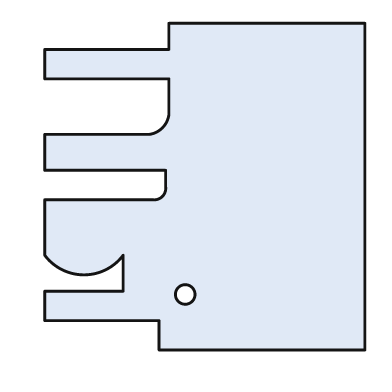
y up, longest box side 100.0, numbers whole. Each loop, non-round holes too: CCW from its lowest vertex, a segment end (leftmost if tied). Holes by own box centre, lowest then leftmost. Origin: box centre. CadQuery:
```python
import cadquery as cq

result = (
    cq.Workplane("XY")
    .moveTo(-14.0, -50.0)
    .lineTo(49.0, -50.0)
    .lineTo(49.0, 50.0)
    .lineTo(-11.0, 50.0)
    .lineTo(-11.0, 42.0)
    .lineTo(-49.0, 42.0)
    .lineTo(-49.0, 33.0)
    .lineTo(-11.0, 33.0)
    .lineTo(-11.0, 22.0)
    .threePointArc((-13.0, 18.0), (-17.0, 16.0))
    .lineTo(-49.0, 16.0)
    .lineTo(-49.0, 5.0)
    .lineTo(-12.0, 5.0)
    .lineTo(-12.0, 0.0)
    .threePointArc((-13.0, -3.0), (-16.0, -4.0))
    .lineTo(-49.0, -4.0)
    .lineTo(-49.0, -21.0)
    .threePointArc((-37.0, -27.0), (-25.0, -21.0))
    .lineTo(-25.0, -32.0)
    .lineTo(-49.0, -32.0)
    .lineTo(-49.0, -41.0)
    .lineTo(-14.0, -41.0)
    .close()
    .moveTo(-6.0, -33.0)
    .circle(3.0)
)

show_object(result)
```